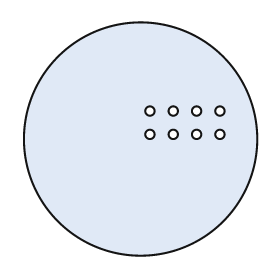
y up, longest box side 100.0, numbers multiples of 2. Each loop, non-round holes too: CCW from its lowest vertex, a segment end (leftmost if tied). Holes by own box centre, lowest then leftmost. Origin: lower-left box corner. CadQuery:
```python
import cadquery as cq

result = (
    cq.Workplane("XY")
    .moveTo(50.0, 50.0)
    .circle(50.0)
    .moveTo(54.0, 52.0)
    .circle(2.0)
    .moveTo(64.0, 52.0)
    .circle(2.0)
    .moveTo(74.0, 52.0)
    .circle(2.0)
    .moveTo(84.0, 52.0)
    .circle(2.0)
    .moveTo(54.0, 62.0)
    .circle(2.0)
    .moveTo(64.0, 62.0)
    .circle(2.0)
    .moveTo(74.0, 62.0)
    .circle(2.0)
    .moveTo(84.0, 62.0)
    .circle(2.0)
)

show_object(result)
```